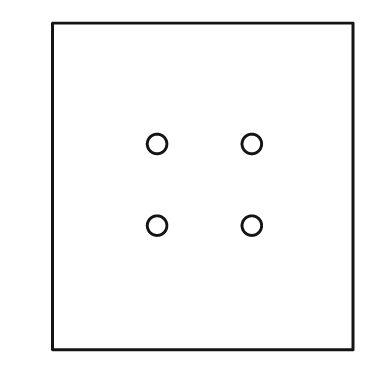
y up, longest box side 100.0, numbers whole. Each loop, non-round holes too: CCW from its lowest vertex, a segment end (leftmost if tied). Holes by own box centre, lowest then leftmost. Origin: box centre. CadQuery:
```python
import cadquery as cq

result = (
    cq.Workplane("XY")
    .moveTo(-46.0, -50.0)
    .lineTo(46.0, -50.0)
    .lineTo(46.0, 50.0)
    .lineTo(-46.0, 50.0)
    .close()
    .moveTo(-14.0, -12.0)
    .circle(3.0)
    .moveTo(15.0, -12.0)
    .circle(3.0)
    .moveTo(-14.0, 13.0)
    .circle(3.0)
    .moveTo(15.0, 13.0)
    .circle(3.0)
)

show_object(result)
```